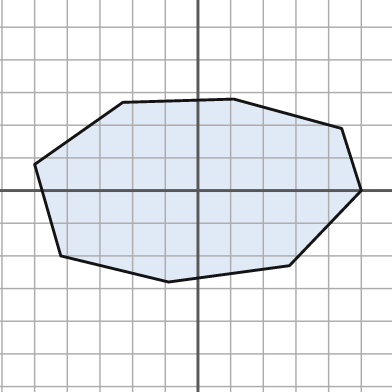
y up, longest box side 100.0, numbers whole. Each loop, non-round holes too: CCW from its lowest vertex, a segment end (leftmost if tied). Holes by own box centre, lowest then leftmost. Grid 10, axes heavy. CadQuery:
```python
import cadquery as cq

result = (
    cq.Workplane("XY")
    .moveTo(-9.0, -28.0)
    .lineTo(28.0, -23.0)
    .lineTo(50.0, 0.0)
    .lineTo(44.0, 19.0)
    .lineTo(11.0, 28.0)
    .lineTo(-23.0, 27.0)
    .lineTo(-50.0, 8.0)
    .lineTo(-42.0, -20.0)
    .close()
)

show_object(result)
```